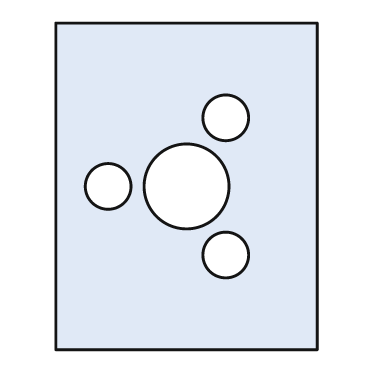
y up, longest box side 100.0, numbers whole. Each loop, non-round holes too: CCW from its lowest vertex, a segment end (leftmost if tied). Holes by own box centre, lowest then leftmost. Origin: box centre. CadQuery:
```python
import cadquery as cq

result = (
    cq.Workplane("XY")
    .moveTo(-40.0, -50.0)
    .lineTo(40.0, -50.0)
    .lineTo(40.0, 50.0)
    .lineTo(-40.0, 50.0)
    .close()
    .moveTo(12.0, -21.0)
    .circle(7.0)
    .moveTo(-24.0, 0.0)
    .circle(7.0)
    .moveTo(0.0, 0.0)
    .circle(13.0)
    .moveTo(12.0, 21.0)
    .circle(7.0)
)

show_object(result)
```